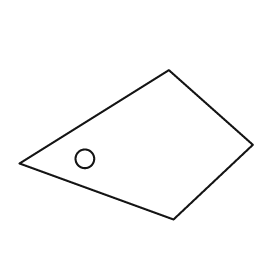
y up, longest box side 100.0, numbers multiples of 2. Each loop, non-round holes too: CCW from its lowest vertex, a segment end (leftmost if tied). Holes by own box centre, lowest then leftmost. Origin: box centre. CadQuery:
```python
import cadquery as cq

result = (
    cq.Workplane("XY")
    .moveTo(16.0, -32.0)
    .lineTo(50.0, 0.0)
    .lineTo(14.0, 32.0)
    .lineTo(-50.0, -8.0)
    .close()
    .moveTo(-22.0, -6.0)
    .circle(4.0)
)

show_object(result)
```